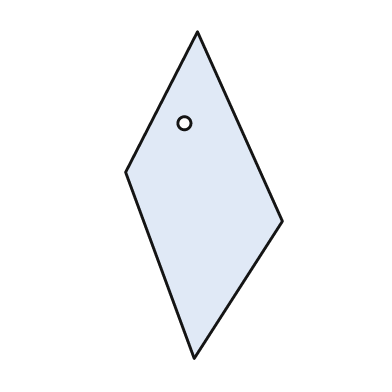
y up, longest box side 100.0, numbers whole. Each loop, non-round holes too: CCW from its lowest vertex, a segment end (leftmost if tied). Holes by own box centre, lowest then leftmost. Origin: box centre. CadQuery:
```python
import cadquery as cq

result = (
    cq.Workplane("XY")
    .moveTo(-3.0, -50.0)
    .lineTo(24.0, -8.0)
    .lineTo(-2.0, 50.0)
    .lineTo(-24.0, 7.0)
    .close()
    .moveTo(-6.0, 22.0)
    .circle(2.0)
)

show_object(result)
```